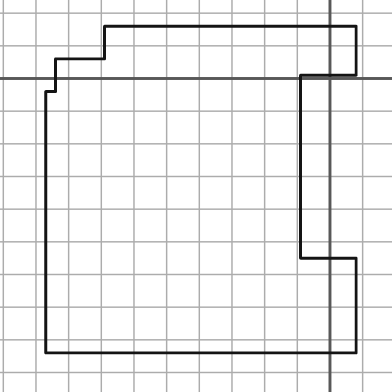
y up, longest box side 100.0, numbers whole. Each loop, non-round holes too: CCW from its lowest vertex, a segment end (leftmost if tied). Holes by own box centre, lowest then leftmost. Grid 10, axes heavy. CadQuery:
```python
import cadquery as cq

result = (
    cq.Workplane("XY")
    .moveTo(-87.0, -84.0)
    .lineTo(8.0, -84.0)
    .lineTo(8.0, -55.0)
    .lineTo(-9.0, -55.0)
    .lineTo(-9.0, 1.0)
    .lineTo(8.0, 1.0)
    .lineTo(8.0, 16.0)
    .lineTo(-69.0, 16.0)
    .lineTo(-69.0, 6.0)
    .lineTo(-84.0, 6.0)
    .lineTo(-84.0, -4.0)
    .lineTo(-87.0, -4.0)
    .close()
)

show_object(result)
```